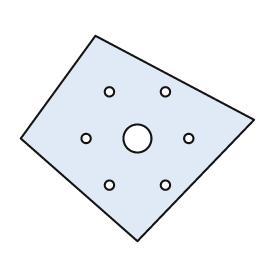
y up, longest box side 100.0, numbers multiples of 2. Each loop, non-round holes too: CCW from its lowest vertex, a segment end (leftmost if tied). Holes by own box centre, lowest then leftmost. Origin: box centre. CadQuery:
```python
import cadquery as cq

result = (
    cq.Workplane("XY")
    .moveTo(0.0, -44.0)
    .lineTo(50.0, 8.0)
    .lineTo(-18.0, 44.0)
    .lineTo(-50.0, 0.0)
    .close()
    .moveTo(-12.0, -20.0)
    .circle(2.0)
    .moveTo(12.0, -20.0)
    .circle(2.0)
    .moveTo(-22.0, 0.0)
    .circle(2.0)
    .moveTo(0.0, 0.0)
    .circle(6.0)
    .moveTo(22.0, 0.0)
    .circle(2.0)
    .moveTo(-12.0, 20.0)
    .circle(2.0)
    .moveTo(12.0, 20.0)
    .circle(2.0)
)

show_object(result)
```